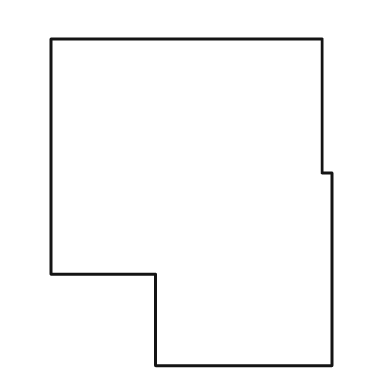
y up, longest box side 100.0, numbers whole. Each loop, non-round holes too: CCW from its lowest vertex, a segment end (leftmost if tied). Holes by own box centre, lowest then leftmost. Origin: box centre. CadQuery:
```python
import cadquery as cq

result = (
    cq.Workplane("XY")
    .moveTo(-11.0, -50.0)
    .lineTo(43.0, -50.0)
    .lineTo(43.0, 9.0)
    .lineTo(40.0, 9.0)
    .lineTo(40.0, 50.0)
    .lineTo(-43.0, 50.0)
    .lineTo(-43.0, -22.0)
    .lineTo(-11.0, -22.0)
    .close()
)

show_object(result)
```